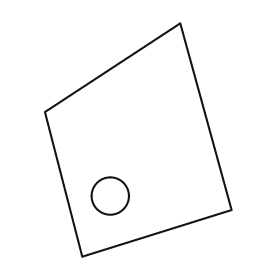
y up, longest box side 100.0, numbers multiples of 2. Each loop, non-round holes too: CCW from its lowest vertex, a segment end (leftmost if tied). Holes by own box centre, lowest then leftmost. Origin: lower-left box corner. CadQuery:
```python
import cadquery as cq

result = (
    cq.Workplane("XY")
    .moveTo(16.0, 0.0)
    .lineTo(80.0, 20.0)
    .lineTo(58.0, 100.0)
    .lineTo(0.0, 62.0)
    .close()
    .moveTo(28.0, 26.0)
    .circle(8.0)
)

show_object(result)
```